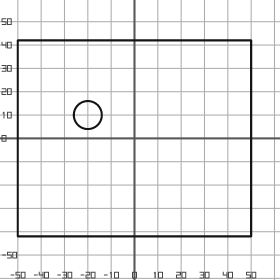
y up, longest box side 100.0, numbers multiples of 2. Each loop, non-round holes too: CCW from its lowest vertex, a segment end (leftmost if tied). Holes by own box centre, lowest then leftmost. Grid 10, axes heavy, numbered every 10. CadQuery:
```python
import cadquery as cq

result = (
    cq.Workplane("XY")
    .moveTo(-50.0, -42.0)
    .lineTo(50.0, -42.0)
    .lineTo(50.0, 42.0)
    .lineTo(-50.0, 42.0)
    .close()
    .moveTo(-20.0, 10.0)
    .circle(6.0)
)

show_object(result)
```